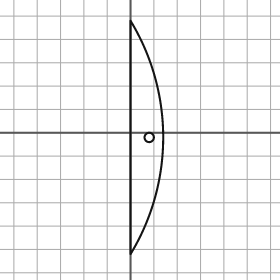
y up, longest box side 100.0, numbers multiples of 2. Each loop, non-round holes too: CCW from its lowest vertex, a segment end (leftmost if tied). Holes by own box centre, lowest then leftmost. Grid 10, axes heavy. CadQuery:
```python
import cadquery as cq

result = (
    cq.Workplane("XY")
    .moveTo(0.0, -52.0)
    .threePointArc((14.0, -2.0), (0.0, 48.0))
    .close()
    .moveTo(8.0, -2.0)
    .circle(2.0)
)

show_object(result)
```